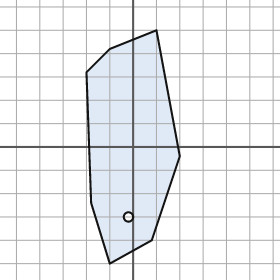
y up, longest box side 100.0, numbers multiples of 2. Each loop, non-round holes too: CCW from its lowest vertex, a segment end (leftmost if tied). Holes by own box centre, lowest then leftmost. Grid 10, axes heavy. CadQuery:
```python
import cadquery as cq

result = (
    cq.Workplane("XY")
    .moveTo(-10.0, -50.0)
    .lineTo(8.0, -40.0)
    .lineTo(20.0, -4.0)
    .lineTo(10.0, 50.0)
    .lineTo(-10.0, 42.0)
    .lineTo(-20.0, 32.0)
    .lineTo(-18.0, -24.0)
    .close()
    .moveTo(-2.0, -30.0)
    .circle(2.0)
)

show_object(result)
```